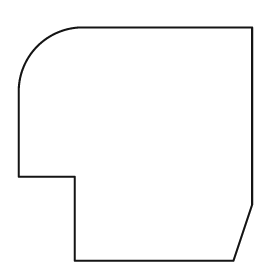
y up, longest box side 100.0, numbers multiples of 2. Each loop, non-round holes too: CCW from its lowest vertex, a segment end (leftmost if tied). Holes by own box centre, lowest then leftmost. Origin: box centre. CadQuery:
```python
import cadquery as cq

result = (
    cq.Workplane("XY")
    .moveTo(-26.0, -50.0)
    .lineTo(42.0, -50.0)
    .lineTo(50.0, -26.0)
    .lineTo(50.0, 50.0)
    .lineTo(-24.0, 50.0)
    .threePointArc((-42.0, 42.0), (-50.0, 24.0))
    .lineTo(-50.0, -14.0)
    .lineTo(-26.0, -14.0)
    .close()
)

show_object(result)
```